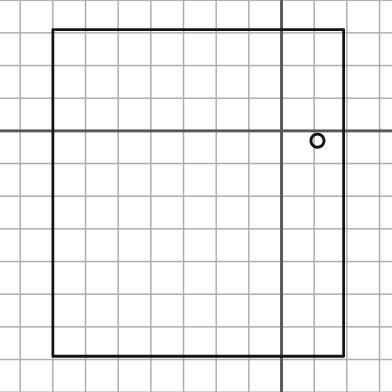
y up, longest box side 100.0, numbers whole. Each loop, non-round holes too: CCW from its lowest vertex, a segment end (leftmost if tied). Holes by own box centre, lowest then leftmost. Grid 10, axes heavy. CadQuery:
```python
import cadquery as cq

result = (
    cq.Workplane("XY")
    .moveTo(-70.0, -69.0)
    .lineTo(19.0, -69.0)
    .lineTo(19.0, 31.0)
    .lineTo(-70.0, 31.0)
    .close()
    .moveTo(11.0, -3.0)
    .circle(2.0)
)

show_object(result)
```